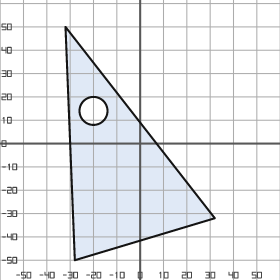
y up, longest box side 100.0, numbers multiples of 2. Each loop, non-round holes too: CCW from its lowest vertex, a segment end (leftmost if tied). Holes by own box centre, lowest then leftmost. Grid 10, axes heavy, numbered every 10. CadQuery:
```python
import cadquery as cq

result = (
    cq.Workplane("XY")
    .moveTo(-28.0, -50.0)
    .lineTo(32.0, -32.0)
    .lineTo(-32.0, 50.0)
    .close()
    .moveTo(-20.0, 14.0)
    .circle(6.0)
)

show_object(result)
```